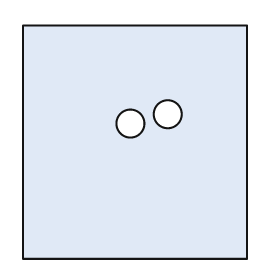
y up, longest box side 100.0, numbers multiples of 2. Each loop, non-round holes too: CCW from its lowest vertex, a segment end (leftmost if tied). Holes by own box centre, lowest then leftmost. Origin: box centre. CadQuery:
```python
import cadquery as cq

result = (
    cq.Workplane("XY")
    .moveTo(-48.0, -50.0)
    .lineTo(48.0, -50.0)
    .lineTo(48.0, 50.0)
    .lineTo(-48.0, 50.0)
    .close()
    .moveTo(-2.0, 8.0)
    .circle(6.0)
    .moveTo(14.0, 12.0)
    .circle(6.0)
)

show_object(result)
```